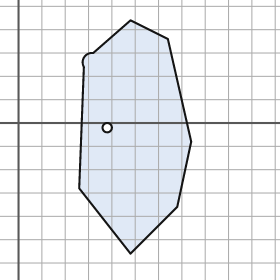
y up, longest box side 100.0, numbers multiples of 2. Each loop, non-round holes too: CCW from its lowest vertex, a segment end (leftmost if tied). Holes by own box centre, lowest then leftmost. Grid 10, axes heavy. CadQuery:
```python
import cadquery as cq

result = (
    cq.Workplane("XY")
    .moveTo(48.0, -56.0)
    .lineTo(68.0, -36.0)
    .lineTo(74.0, -8.0)
    .lineTo(64.0, 36.0)
    .lineTo(48.0, 44.0)
    .lineTo(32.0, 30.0)
    .threePointArc((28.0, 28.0), (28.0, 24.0))
    .lineTo(26.0, -28.0)
    .close()
    .moveTo(38.0, -2.0)
    .circle(2.0)
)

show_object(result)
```